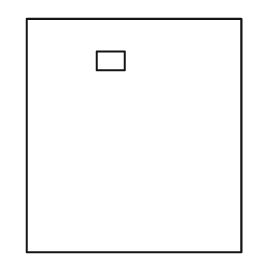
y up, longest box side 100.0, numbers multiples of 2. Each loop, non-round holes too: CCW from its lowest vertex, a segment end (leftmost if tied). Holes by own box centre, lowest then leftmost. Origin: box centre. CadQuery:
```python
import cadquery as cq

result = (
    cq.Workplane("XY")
    .moveTo(-46.0, -50.0)
    .lineTo(46.0, -50.0)
    .lineTo(46.0, 50.0)
    .lineTo(-46.0, 50.0)
    .close()
    .moveTo(-16.0, 28.0)
    .lineTo(-4.0, 28.0)
    .lineTo(-4.0, 36.0)
    .lineTo(-16.0, 36.0)
    .close()
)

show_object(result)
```